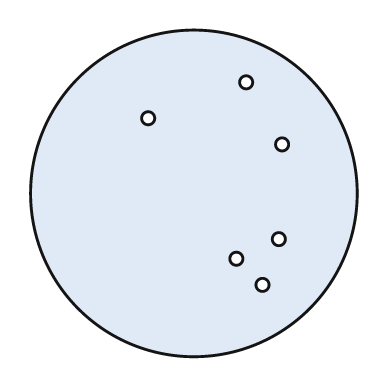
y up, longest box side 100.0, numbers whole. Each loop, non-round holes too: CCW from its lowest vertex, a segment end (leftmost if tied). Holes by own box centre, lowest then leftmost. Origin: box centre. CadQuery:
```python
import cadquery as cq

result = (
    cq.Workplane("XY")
    .moveTo(0.0, 0.0)
    .circle(50.0)
    .moveTo(21.0, -28.0)
    .circle(2.0)
    .moveTo(13.0, -20.0)
    .circle(2.0)
    .moveTo(26.0, -14.0)
    .circle(2.0)
    .moveTo(27.0, 15.0)
    .circle(2.0)
    .moveTo(-14.0, 23.0)
    .circle(2.0)
    .moveTo(16.0, 34.0)
    .circle(2.0)
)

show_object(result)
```